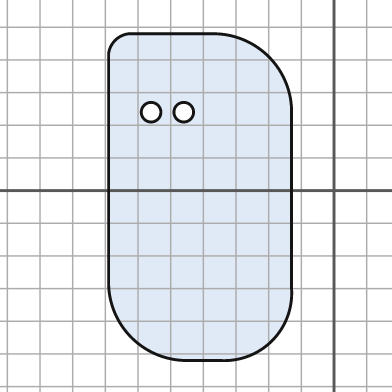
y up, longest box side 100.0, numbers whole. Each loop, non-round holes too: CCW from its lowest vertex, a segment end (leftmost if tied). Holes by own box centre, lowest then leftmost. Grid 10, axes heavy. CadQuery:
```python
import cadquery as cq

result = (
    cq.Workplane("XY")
    .moveTo(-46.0, -52.0)
    .lineTo(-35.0, -52.0)
    .threePointArc((-19.0, -46.0), (-13.0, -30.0))
    .lineTo(-13.0, 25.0)
    .threePointArc((-20.0, 41.0), (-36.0, 48.0))
    .lineTo(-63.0, 48.0)
    .threePointArc((-67.0, 46.0), (-69.0, 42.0))
    .lineTo(-69.0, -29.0)
    .threePointArc((-62.0, -45.0), (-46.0, -52.0))
    .close()
    .moveTo(-56.0, 24.0)
    .circle(3.0)
    .moveTo(-46.0, 24.0)
    .circle(3.0)
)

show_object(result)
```